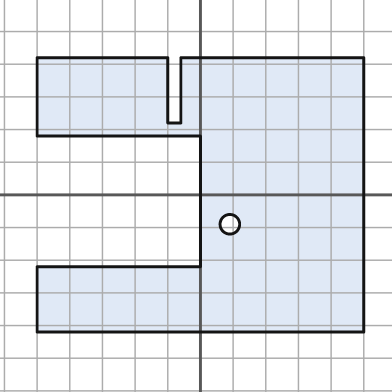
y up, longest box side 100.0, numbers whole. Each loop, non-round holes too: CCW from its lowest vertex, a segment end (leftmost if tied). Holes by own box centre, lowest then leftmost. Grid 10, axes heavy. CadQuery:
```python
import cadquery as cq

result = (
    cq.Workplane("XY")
    .moveTo(-50.0, -42.0)
    .lineTo(50.0, -42.0)
    .lineTo(50.0, 42.0)
    .lineTo(-6.0, 42.0)
    .lineTo(-6.0, 22.0)
    .lineTo(-10.0, 22.0)
    .lineTo(-10.0, 42.0)
    .lineTo(-50.0, 42.0)
    .lineTo(-50.0, 18.0)
    .lineTo(0.0, 18.0)
    .lineTo(0.0, -22.0)
    .lineTo(-50.0, -22.0)
    .close()
    .moveTo(9.0, -9.0)
    .circle(3.0)
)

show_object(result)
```